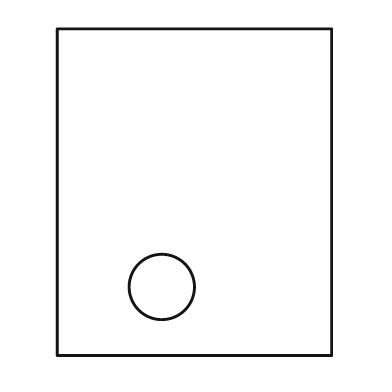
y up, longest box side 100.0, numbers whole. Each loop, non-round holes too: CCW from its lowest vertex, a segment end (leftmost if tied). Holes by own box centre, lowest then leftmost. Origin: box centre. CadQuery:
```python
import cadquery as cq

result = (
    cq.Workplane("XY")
    .moveTo(-42.0, -50.0)
    .lineTo(42.0, -50.0)
    .lineTo(42.0, 50.0)
    .lineTo(-42.0, 50.0)
    .close()
    .moveTo(-10.0, -29.0)
    .circle(10.0)
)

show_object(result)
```